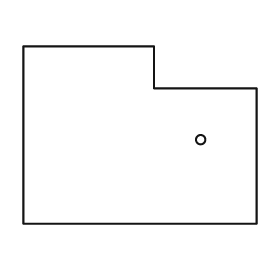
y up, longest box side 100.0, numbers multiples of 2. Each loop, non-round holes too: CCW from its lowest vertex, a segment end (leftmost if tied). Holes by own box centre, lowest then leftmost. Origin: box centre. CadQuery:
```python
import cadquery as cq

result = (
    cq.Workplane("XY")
    .moveTo(-50.0, -38.0)
    .lineTo(50.0, -38.0)
    .lineTo(50.0, 20.0)
    .lineTo(6.0, 20.0)
    .lineTo(6.0, 38.0)
    .lineTo(-50.0, 38.0)
    .close()
    .moveTo(26.0, -2.0)
    .circle(2.0)
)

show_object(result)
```